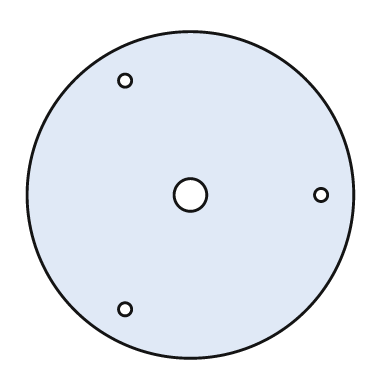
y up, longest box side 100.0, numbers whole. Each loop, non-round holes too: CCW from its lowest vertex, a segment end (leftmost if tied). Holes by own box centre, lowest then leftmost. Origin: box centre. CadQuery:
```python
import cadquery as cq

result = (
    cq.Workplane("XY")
    .moveTo(0.0, 0.0)
    .circle(50.0)
    .moveTo(-20.0, -35.0)
    .circle(2.0)
    .moveTo(0.0, 0.0)
    .circle(5.0)
    .moveTo(40.0, 0.0)
    .circle(2.0)
    .moveTo(-20.0, 35.0)
    .circle(2.0)
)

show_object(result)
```